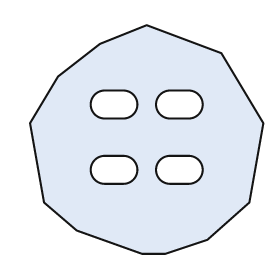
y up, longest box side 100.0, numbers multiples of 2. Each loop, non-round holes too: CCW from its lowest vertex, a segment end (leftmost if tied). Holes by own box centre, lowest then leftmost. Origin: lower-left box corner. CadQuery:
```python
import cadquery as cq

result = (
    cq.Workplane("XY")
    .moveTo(48.0, 0.0)
    .lineTo(58.0, 0.0)
    .lineTo(76.0, 6.0)
    .lineTo(94.0, 22.0)
    .lineTo(100.0, 56.0)
    .lineTo(82.0, 86.0)
    .lineTo(50.0, 98.0)
    .lineTo(30.0, 90.0)
    .lineTo(12.0, 76.0)
    .lineTo(0.0, 56.0)
    .lineTo(6.0, 22.0)
    .lineTo(20.0, 10.0)
    .close()
    .moveTo(32.0, 30.0)
    .lineTo(40.0, 30.0)
    .threePointArc((46.0, 36.0), (40.0, 42.0))
    .lineTo(32.0, 42.0)
    .threePointArc((26.0, 36.0), (32.0, 30.0))
    .close()
    .moveTo(60.0, 30.0)
    .lineTo(68.0, 30.0)
    .threePointArc((74.0, 36.0), (68.0, 42.0))
    .lineTo(60.0, 42.0)
    .threePointArc((54.0, 36.0), (60.0, 30.0))
    .close()
    .moveTo(32.0, 58.0)
    .lineTo(40.0, 58.0)
    .threePointArc((46.0, 64.0), (40.0, 70.0))
    .lineTo(32.0, 70.0)
    .threePointArc((26.0, 64.0), (32.0, 58.0))
    .close()
    .moveTo(60.0, 58.0)
    .lineTo(68.0, 58.0)
    .threePointArc((74.0, 64.0), (68.0, 70.0))
    .lineTo(60.0, 70.0)
    .threePointArc((54.0, 64.0), (60.0, 58.0))
    .close()
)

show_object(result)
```